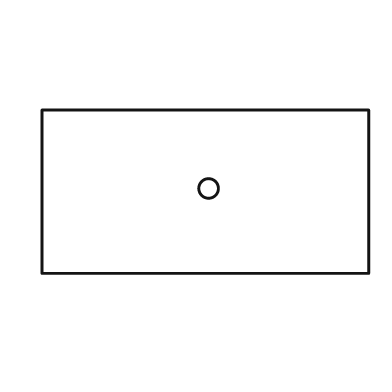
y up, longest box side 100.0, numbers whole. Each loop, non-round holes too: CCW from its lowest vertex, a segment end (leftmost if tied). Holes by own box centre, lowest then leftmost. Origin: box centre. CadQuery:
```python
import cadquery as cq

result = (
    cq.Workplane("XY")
    .moveTo(-50.0, -25.0)
    .lineTo(50.0, -25.0)
    .lineTo(50.0, 25.0)
    .lineTo(-50.0, 25.0)
    .close()
    .moveTo(1.0, 1.0)
    .circle(3.0)
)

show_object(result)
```